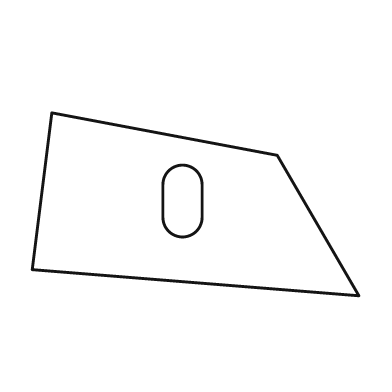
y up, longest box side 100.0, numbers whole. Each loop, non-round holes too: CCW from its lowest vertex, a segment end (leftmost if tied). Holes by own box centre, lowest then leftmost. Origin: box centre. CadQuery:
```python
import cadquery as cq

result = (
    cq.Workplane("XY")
    .moveTo(50.0, -28.0)
    .lineTo(25.0, 15.0)
    .lineTo(-44.0, 28.0)
    .lineTo(-50.0, -20.0)
    .close()
    .moveTo(-10.0, -4.0)
    .threePointArc((-4.0, -10.0), (2.0, -4.0))
    .lineTo(2.0, 6.0)
    .threePointArc((-4.0, 12.0), (-10.0, 6.0))
    .close()
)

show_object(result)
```